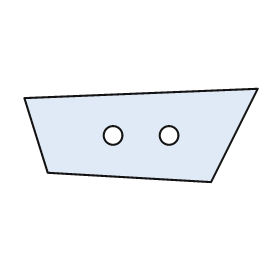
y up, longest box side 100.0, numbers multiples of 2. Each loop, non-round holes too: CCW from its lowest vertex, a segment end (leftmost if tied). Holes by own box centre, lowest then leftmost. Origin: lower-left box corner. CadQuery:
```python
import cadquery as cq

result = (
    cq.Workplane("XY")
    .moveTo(80.0, 0.0)
    .lineTo(100.0, 40.0)
    .lineTo(0.0, 36.0)
    .lineTo(10.0, 4.0)
    .close()
    .moveTo(38.0, 20.0)
    .circle(4.0)
    .moveTo(62.0, 20.0)
    .circle(4.0)
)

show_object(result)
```